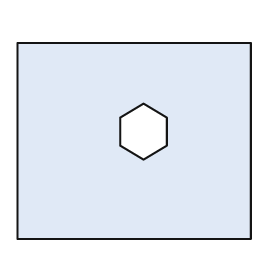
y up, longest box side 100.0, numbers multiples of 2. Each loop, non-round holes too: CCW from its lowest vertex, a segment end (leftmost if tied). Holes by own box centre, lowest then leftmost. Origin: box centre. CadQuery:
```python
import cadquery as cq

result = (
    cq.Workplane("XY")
    .moveTo(-50.0, -42.0)
    .lineTo(50.0, -42.0)
    .lineTo(50.0, 42.0)
    .lineTo(-50.0, 42.0)
    .close()
    .moveTo(4.0, -8.0)
    .lineTo(14.0, -2.0)
    .lineTo(14.0, 10.0)
    .lineTo(4.0, 16.0)
    .lineTo(-6.0, 10.0)
    .lineTo(-6.0, -2.0)
    .close()
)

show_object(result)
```